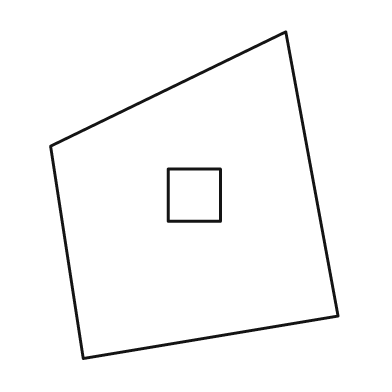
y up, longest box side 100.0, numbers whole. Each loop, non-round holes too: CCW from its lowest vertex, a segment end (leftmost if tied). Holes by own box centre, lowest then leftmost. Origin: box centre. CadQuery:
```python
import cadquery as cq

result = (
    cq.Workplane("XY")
    .moveTo(-34.0, -50.0)
    .lineTo(44.0, -37.0)
    .lineTo(28.0, 50.0)
    .lineTo(-44.0, 15.0)
    .close()
    .moveTo(-8.0, -8.0)
    .lineTo(8.0, -8.0)
    .lineTo(8.0, 8.0)
    .lineTo(-8.0, 8.0)
    .close()
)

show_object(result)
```